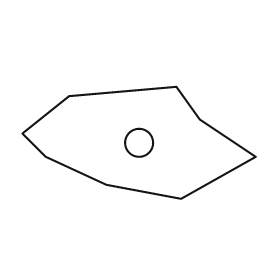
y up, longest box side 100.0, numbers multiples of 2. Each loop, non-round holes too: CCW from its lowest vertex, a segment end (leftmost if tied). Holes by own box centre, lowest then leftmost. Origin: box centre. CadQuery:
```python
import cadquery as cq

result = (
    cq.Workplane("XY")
    .moveTo(18.0, -24.0)
    .lineTo(50.0, -6.0)
    .lineTo(26.0, 10.0)
    .lineTo(16.0, 24.0)
    .lineTo(-30.0, 20.0)
    .lineTo(-50.0, 4.0)
    .lineTo(-40.0, -6.0)
    .lineTo(-14.0, -18.0)
    .close()
    .moveTo(0.0, 0.0)
    .circle(6.0)
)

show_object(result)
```